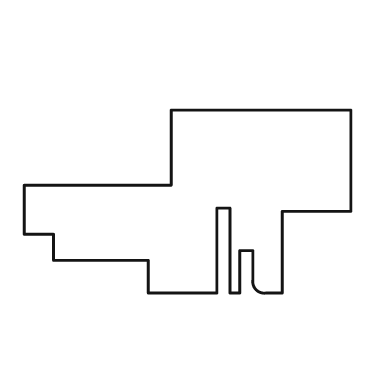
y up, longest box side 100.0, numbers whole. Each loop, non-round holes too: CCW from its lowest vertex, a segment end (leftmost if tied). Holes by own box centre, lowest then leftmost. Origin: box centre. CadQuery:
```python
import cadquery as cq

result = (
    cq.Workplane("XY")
    .moveTo(-12.0, -28.0)
    .lineTo(9.0, -28.0)
    .lineTo(9.0, -2.0)
    .lineTo(13.0, -2.0)
    .lineTo(13.0, -28.0)
    .lineTo(16.0, -28.0)
    .lineTo(16.0, -15.0)
    .lineTo(20.0, -15.0)
    .lineTo(20.0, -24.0)
    .threePointArc((21.0, -27.0), (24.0, -28.0))
    .lineTo(29.0, -28.0)
    .lineTo(29.0, -3.0)
    .lineTo(50.0, -3.0)
    .lineTo(50.0, 28.0)
    .lineTo(-5.0, 28.0)
    .lineTo(-5.0, 5.0)
    .lineTo(-50.0, 5.0)
    .lineTo(-50.0, -10.0)
    .lineTo(-41.0, -10.0)
    .lineTo(-41.0, -18.0)
    .lineTo(-12.0, -18.0)
    .close()
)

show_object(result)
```